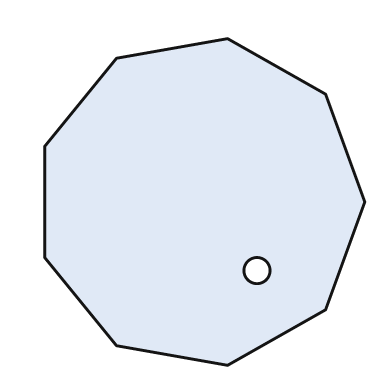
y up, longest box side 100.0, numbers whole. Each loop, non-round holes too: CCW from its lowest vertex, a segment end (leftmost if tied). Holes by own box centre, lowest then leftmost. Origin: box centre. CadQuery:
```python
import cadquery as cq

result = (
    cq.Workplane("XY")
    .moveTo(7.0, -50.0)
    .lineTo(37.0, -33.0)
    .lineTo(49.0, 0.0)
    .lineTo(37.0, 33.0)
    .lineTo(7.0, 50.0)
    .lineTo(-27.0, 44.0)
    .lineTo(-49.0, 17.0)
    .lineTo(-49.0, -17.0)
    .lineTo(-27.0, -44.0)
    .close()
    .moveTo(16.0, -21.0)
    .circle(4.0)
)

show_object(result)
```